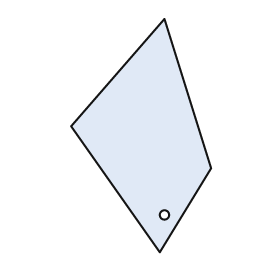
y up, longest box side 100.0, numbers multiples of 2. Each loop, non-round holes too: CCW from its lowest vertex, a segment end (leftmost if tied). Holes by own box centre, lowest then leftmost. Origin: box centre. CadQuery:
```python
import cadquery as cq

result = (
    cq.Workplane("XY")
    .moveTo(8.0, -50.0)
    .lineTo(30.0, -14.0)
    .lineTo(10.0, 50.0)
    .lineTo(-30.0, 4.0)
    .close()
    .moveTo(10.0, -34.0)
    .circle(2.0)
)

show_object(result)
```